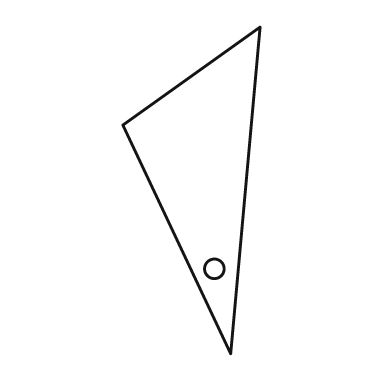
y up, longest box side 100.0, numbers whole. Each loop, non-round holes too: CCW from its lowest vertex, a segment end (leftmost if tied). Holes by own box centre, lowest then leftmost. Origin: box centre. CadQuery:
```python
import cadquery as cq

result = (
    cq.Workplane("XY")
    .moveTo(12.0, -50.0)
    .lineTo(21.0, 50.0)
    .lineTo(-21.0, 20.0)
    .close()
    .moveTo(7.0, -24.0)
    .circle(3.0)
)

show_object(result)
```